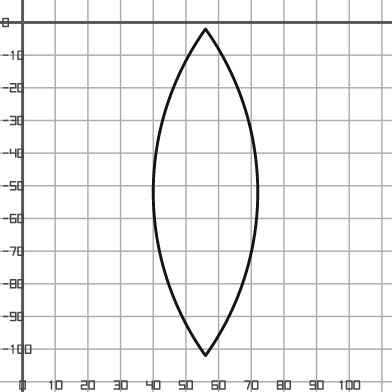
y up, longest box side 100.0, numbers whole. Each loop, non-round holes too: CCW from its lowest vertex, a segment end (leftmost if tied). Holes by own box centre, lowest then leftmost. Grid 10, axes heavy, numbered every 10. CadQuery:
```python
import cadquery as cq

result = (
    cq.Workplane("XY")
    .moveTo(56.0, -102.0)
    .threePointArc((72.0, -52.0), (56.0, -2.0))
    .threePointArc((40.0, -52.0), (56.0, -102.0))
    .close()
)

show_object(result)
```